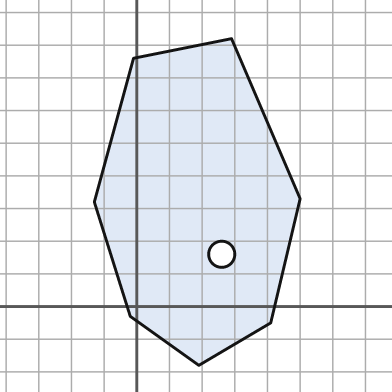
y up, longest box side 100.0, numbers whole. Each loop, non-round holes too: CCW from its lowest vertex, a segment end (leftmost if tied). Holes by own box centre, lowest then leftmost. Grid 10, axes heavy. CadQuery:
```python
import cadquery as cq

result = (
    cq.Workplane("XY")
    .moveTo(19.0, -18.0)
    .lineTo(41.0, -5.0)
    .lineTo(50.0, 33.0)
    .lineTo(29.0, 82.0)
    .lineTo(-1.0, 76.0)
    .lineTo(-13.0, 32.0)
    .lineTo(-2.0, -3.0)
    .close()
    .moveTo(26.0, 16.0)
    .circle(4.0)
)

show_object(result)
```